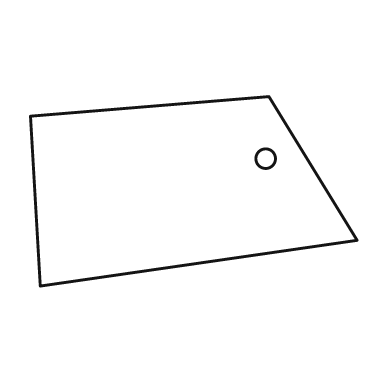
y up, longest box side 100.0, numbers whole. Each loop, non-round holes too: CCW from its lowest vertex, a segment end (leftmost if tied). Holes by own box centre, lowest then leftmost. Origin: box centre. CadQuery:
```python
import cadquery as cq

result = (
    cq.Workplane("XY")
    .moveTo(-47.0, -29.0)
    .lineTo(50.0, -15.0)
    .lineTo(23.0, 29.0)
    .lineTo(-50.0, 23.0)
    .close()
    .moveTo(22.0, 10.0)
    .circle(3.0)
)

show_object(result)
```